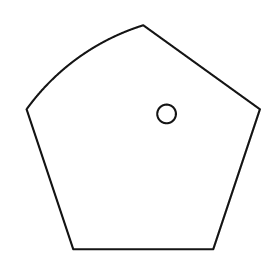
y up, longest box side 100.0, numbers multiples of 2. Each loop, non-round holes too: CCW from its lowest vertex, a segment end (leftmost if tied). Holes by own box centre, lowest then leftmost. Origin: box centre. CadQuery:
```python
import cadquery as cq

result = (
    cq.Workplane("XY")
    .moveTo(-30.0, -48.0)
    .lineTo(30.0, -48.0)
    .lineTo(50.0, 12.0)
    .lineTo(0.0, 48.0)
    .threePointArc((-28.0, 34.0), (-50.0, 12.0))
    .close()
    .moveTo(10.0, 10.0)
    .circle(4.0)
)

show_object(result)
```